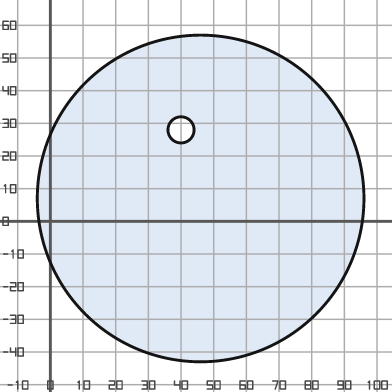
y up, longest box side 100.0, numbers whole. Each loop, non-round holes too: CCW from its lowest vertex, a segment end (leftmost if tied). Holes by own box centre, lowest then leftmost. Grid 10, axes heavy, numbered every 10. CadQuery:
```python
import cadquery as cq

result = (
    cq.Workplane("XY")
    .moveTo(46.0, 7.0)
    .circle(50.0)
    .moveTo(40.0, 28.0)
    .circle(4.0)
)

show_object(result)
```